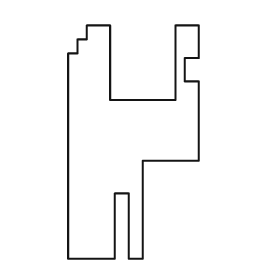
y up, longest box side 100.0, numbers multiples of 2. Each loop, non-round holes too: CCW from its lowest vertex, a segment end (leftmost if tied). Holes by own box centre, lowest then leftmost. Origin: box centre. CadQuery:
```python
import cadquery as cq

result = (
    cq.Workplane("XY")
    .moveTo(-28.0, -50.0)
    .lineTo(-8.0, -50.0)
    .lineTo(-8.0, -22.0)
    .lineTo(-2.0, -22.0)
    .lineTo(-2.0, -50.0)
    .lineTo(4.0, -50.0)
    .lineTo(4.0, -8.0)
    .lineTo(28.0, -8.0)
    .lineTo(28.0, 26.0)
    .lineTo(22.0, 26.0)
    .lineTo(22.0, 36.0)
    .lineTo(28.0, 36.0)
    .lineTo(28.0, 50.0)
    .lineTo(18.0, 50.0)
    .lineTo(18.0, 18.0)
    .lineTo(-10.0, 18.0)
    .lineTo(-10.0, 50.0)
    .lineTo(-20.0, 50.0)
    .lineTo(-20.0, 44.0)
    .lineTo(-24.0, 44.0)
    .lineTo(-24.0, 38.0)
    .lineTo(-28.0, 38.0)
    .close()
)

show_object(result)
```